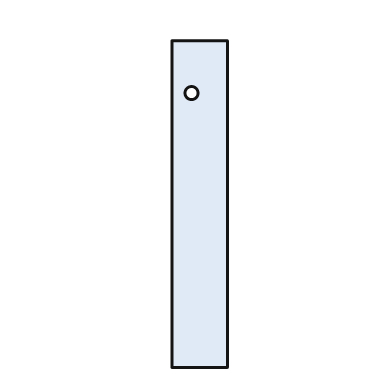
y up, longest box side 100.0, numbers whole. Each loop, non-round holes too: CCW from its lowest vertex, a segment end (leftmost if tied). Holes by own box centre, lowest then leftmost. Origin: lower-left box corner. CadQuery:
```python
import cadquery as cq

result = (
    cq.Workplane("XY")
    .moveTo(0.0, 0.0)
    .lineTo(17.0, 0.0)
    .lineTo(17.0, 100.0)
    .lineTo(0.0, 100.0)
    .close()
    .moveTo(6.0, 84.0)
    .circle(2.0)
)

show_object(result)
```